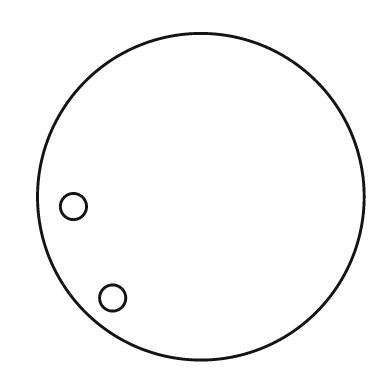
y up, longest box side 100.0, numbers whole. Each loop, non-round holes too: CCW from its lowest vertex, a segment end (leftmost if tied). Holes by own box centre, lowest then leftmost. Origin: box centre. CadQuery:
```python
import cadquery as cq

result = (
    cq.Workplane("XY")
    .moveTo(0.0, 0.0)
    .circle(50.0)
    .moveTo(-27.0, -31.0)
    .circle(4.0)
    .moveTo(-39.0, -3.0)
    .circle(4.0)
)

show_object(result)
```